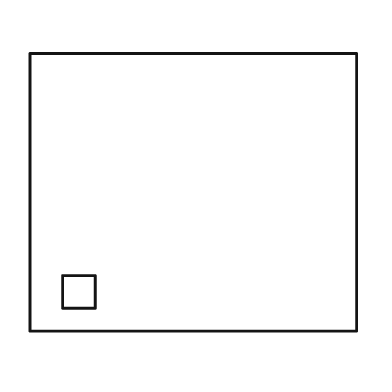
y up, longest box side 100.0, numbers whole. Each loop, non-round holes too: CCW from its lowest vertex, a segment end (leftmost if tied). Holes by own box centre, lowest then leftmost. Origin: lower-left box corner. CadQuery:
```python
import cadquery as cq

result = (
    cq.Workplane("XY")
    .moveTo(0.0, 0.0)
    .lineTo(100.0, 0.0)
    .lineTo(100.0, 85.0)
    .lineTo(0.0, 85.0)
    .close()
    .moveTo(10.0, 7.0)
    .lineTo(20.0, 7.0)
    .lineTo(20.0, 17.0)
    .lineTo(10.0, 17.0)
    .close()
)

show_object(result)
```